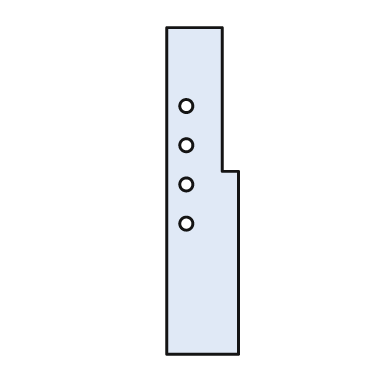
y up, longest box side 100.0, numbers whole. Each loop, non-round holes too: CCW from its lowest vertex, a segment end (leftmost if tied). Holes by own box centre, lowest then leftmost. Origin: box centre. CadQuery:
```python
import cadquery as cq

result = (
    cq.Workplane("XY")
    .moveTo(-11.0, -50.0)
    .lineTo(11.0, -50.0)
    .lineTo(11.0, 6.0)
    .lineTo(6.0, 6.0)
    .lineTo(6.0, 50.0)
    .lineTo(-11.0, 50.0)
    .close()
    .moveTo(-5.0, -10.0)
    .circle(2.0)
    .moveTo(-5.0, 2.0)
    .circle(2.0)
    .moveTo(-5.0, 14.0)
    .circle(2.0)
    .moveTo(-5.0, 26.0)
    .circle(2.0)
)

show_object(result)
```